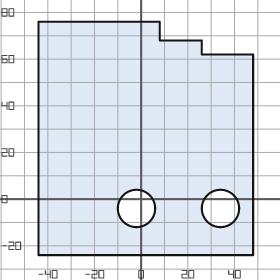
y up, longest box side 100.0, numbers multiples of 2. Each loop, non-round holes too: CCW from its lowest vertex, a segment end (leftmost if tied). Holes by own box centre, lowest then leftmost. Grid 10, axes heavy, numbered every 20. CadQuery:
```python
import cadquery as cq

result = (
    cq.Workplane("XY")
    .moveTo(-44.0, -24.0)
    .lineTo(48.0, -24.0)
    .lineTo(48.0, 62.0)
    .lineTo(26.0, 62.0)
    .lineTo(26.0, 68.0)
    .lineTo(8.0, 68.0)
    .lineTo(8.0, 76.0)
    .lineTo(-44.0, 76.0)
    .close()
    .moveTo(-2.0, -4.0)
    .circle(8.0)
    .moveTo(34.0, -4.0)
    .circle(8.0)
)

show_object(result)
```